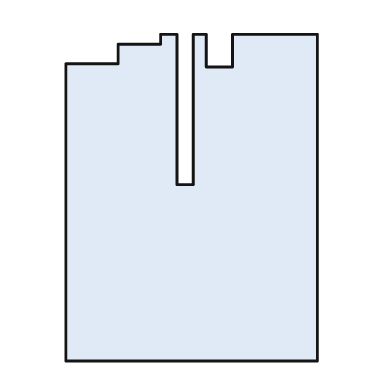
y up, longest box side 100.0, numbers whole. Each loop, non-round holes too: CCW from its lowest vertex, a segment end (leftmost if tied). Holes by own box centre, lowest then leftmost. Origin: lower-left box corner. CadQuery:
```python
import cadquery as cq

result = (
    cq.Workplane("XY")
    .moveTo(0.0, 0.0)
    .lineTo(77.0, 0.0)
    .lineTo(77.0, 100.0)
    .lineTo(51.0, 100.0)
    .lineTo(51.0, 90.0)
    .lineTo(43.0, 90.0)
    .lineTo(43.0, 100.0)
    .lineTo(39.0, 100.0)
    .lineTo(39.0, 54.0)
    .lineTo(34.0, 54.0)
    .lineTo(34.0, 100.0)
    .lineTo(29.0, 100.0)
    .lineTo(29.0, 97.0)
    .lineTo(16.0, 97.0)
    .lineTo(16.0, 91.0)
    .lineTo(0.0, 91.0)
    .close()
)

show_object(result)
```